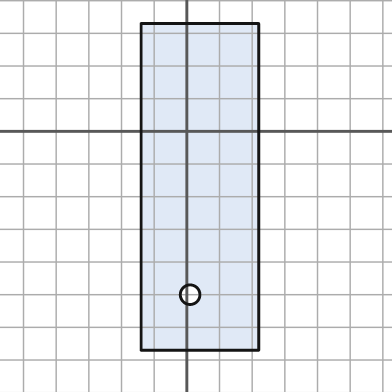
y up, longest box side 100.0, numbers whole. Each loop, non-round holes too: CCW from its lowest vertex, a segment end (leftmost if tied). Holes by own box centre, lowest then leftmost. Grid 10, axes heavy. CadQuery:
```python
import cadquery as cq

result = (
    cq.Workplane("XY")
    .moveTo(-14.0, -67.0)
    .lineTo(22.0, -67.0)
    .lineTo(22.0, 33.0)
    .lineTo(-14.0, 33.0)
    .close()
    .moveTo(1.0, -50.0)
    .circle(3.0)
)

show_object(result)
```